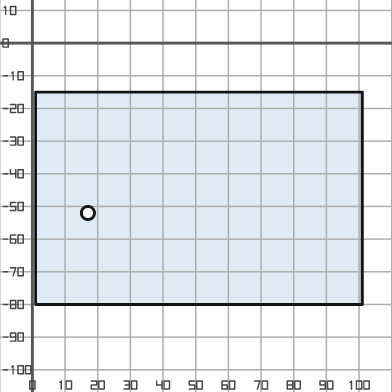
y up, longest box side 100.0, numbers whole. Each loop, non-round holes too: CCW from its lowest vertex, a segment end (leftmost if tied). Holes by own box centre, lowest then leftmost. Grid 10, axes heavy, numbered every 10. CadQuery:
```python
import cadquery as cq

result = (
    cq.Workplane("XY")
    .moveTo(1.0, -80.0)
    .lineTo(101.0, -80.0)
    .lineTo(101.0, -15.0)
    .lineTo(1.0, -15.0)
    .close()
    .moveTo(17.0, -52.0)
    .circle(2.0)
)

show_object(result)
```